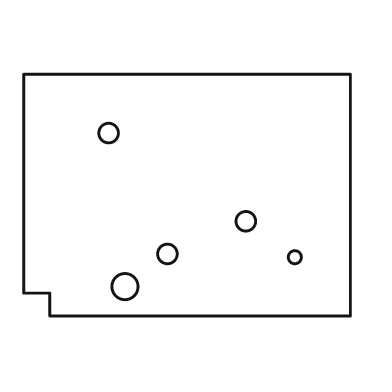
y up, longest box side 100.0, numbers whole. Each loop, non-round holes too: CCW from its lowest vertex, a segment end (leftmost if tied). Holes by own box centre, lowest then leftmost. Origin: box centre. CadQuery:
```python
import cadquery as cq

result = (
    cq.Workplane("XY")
    .moveTo(-42.0, -37.0)
    .lineTo(50.0, -37.0)
    .lineTo(50.0, 37.0)
    .lineTo(-50.0, 37.0)
    .lineTo(-50.0, -30.0)
    .lineTo(-42.0, -30.0)
    .close()
    .moveTo(-19.0, -28.0)
    .circle(4.0)
    .moveTo(33.0, -19.0)
    .circle(2.0)
    .moveTo(-6.0, -18.0)
    .circle(3.0)
    .moveTo(18.0, -8.0)
    .circle(3.0)
    .moveTo(-24.0, 19.0)
    .circle(3.0)
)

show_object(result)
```